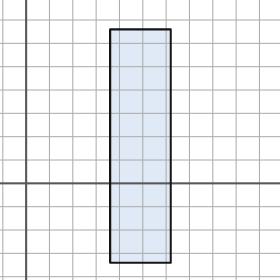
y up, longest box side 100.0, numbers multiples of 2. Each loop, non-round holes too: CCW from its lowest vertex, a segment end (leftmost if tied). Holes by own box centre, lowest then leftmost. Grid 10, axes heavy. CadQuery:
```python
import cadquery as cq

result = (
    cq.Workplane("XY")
    .moveTo(36.0, -34.0)
    .lineTo(62.0, -34.0)
    .lineTo(62.0, 66.0)
    .lineTo(36.0, 66.0)
    .close()
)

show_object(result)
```